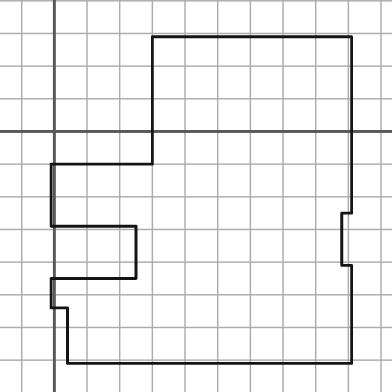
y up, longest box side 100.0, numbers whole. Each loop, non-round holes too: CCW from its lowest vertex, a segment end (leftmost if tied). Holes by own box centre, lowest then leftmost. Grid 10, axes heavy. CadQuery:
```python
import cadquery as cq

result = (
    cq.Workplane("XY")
    .moveTo(4.0, -71.0)
    .lineTo(91.0, -71.0)
    .lineTo(91.0, -41.0)
    .lineTo(88.0, -41.0)
    .lineTo(88.0, -25.0)
    .lineTo(91.0, -25.0)
    .lineTo(91.0, 29.0)
    .lineTo(30.0, 29.0)
    .lineTo(30.0, -10.0)
    .lineTo(-1.0, -10.0)
    .lineTo(-1.0, -29.0)
    .lineTo(25.0, -29.0)
    .lineTo(25.0, -45.0)
    .lineTo(-1.0, -45.0)
    .lineTo(-1.0, -54.0)
    .lineTo(4.0, -54.0)
    .close()
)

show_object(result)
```